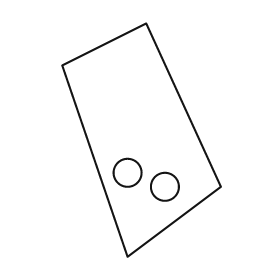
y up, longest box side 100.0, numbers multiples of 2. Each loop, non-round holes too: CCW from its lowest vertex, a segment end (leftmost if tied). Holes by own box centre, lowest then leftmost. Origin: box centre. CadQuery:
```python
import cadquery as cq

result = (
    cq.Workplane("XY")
    .moveTo(-6.0, -50.0)
    .lineTo(34.0, -20.0)
    .lineTo(2.0, 50.0)
    .lineTo(-34.0, 32.0)
    .close()
    .moveTo(10.0, -20.0)
    .circle(6.0)
    .moveTo(-6.0, -14.0)
    .circle(6.0)
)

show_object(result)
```